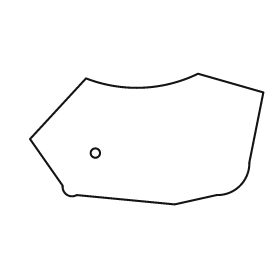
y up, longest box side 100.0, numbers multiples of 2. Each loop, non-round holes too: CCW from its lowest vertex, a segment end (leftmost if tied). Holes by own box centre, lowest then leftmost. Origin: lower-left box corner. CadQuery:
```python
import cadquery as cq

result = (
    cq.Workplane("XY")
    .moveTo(62.0, 0.0)
    .lineTo(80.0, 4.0)
    .threePointArc((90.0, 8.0), (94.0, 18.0))
    .lineTo(100.0, 48.0)
    .lineTo(72.0, 56.0)
    .threePointArc((48.0, 50.0), (24.0, 54.0))
    .lineTo(0.0, 28.0)
    .lineTo(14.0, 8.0)
    .threePointArc((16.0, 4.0), (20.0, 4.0))
    .close()
    .moveTo(28.0, 22.0)
    .circle(2.0)
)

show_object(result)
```